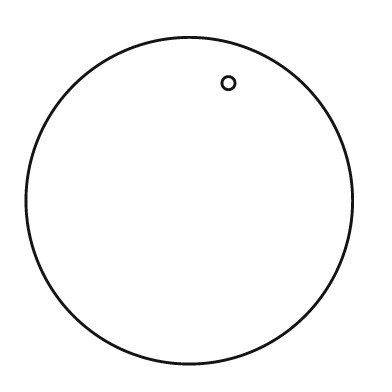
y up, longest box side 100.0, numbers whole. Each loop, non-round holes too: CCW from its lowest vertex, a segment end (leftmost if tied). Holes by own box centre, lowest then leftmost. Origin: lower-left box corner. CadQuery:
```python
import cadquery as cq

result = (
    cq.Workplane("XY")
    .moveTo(50.0, 50.0)
    .circle(50.0)
    .moveTo(62.0, 86.0)
    .circle(2.0)
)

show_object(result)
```